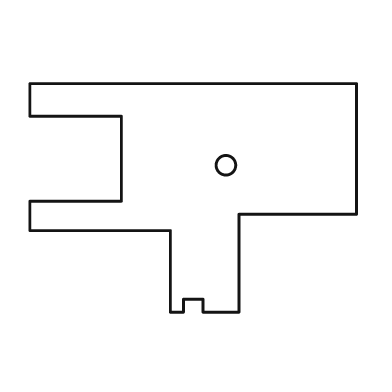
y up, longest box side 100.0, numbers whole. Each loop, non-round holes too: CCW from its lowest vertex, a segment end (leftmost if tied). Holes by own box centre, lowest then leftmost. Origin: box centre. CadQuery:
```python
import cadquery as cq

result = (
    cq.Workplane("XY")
    .moveTo(-7.0, -35.0)
    .lineTo(-3.0, -35.0)
    .lineTo(-3.0, -31.0)
    .lineTo(3.0, -31.0)
    .lineTo(3.0, -35.0)
    .lineTo(14.0, -35.0)
    .lineTo(14.0, -5.0)
    .lineTo(50.0, -5.0)
    .lineTo(50.0, 35.0)
    .lineTo(-50.0, 35.0)
    .lineTo(-50.0, 25.0)
    .lineTo(-22.0, 25.0)
    .lineTo(-22.0, -1.0)
    .lineTo(-50.0, -1.0)
    .lineTo(-50.0, -10.0)
    .lineTo(-7.0, -10.0)
    .close()
    .moveTo(10.0, 10.0)
    .circle(3.0)
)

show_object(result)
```